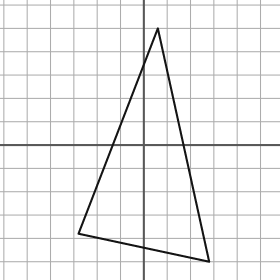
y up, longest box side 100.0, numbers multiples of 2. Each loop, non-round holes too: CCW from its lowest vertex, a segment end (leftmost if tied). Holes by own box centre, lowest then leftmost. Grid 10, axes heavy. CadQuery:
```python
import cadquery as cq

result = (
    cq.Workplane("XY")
    .moveTo(28.0, -50.0)
    .lineTo(6.0, 50.0)
    .lineTo(-28.0, -38.0)
    .close()
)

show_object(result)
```